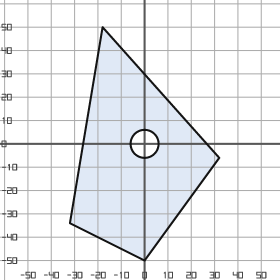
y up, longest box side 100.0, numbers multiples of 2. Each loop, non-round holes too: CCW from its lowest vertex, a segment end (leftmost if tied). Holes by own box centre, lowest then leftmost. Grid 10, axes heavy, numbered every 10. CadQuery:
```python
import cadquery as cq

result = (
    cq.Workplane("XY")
    .moveTo(0.0, -50.0)
    .lineTo(32.0, -6.0)
    .lineTo(-18.0, 50.0)
    .lineTo(-32.0, -34.0)
    .close()
    .moveTo(0.0, 0.0)
    .circle(6.0)
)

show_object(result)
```